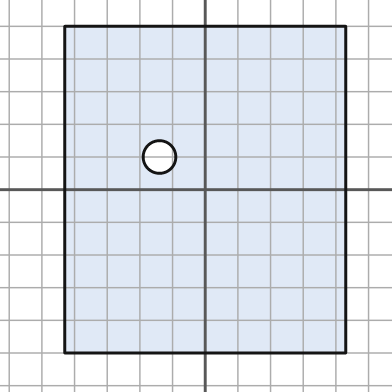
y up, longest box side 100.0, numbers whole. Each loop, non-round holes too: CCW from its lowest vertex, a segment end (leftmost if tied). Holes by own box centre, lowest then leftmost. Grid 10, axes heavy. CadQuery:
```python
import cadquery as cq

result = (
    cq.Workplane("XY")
    .moveTo(-43.0, -50.0)
    .lineTo(43.0, -50.0)
    .lineTo(43.0, 50.0)
    .lineTo(-43.0, 50.0)
    .close()
    .moveTo(-14.0, 10.0)
    .circle(5.0)
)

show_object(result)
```